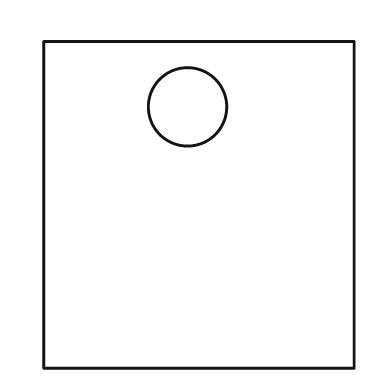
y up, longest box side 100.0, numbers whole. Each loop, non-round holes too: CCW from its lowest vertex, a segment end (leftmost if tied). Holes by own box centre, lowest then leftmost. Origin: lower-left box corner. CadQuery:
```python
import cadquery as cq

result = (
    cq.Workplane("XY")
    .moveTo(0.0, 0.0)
    .lineTo(95.0, 0.0)
    .lineTo(95.0, 100.0)
    .lineTo(0.0, 100.0)
    .close()
    .moveTo(44.0, 80.0)
    .circle(12.0)
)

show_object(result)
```